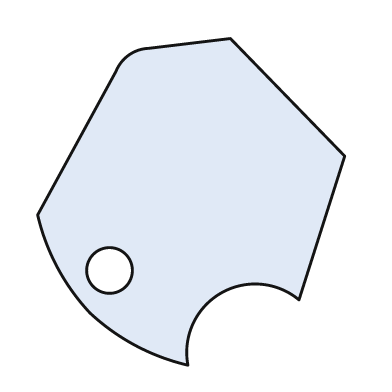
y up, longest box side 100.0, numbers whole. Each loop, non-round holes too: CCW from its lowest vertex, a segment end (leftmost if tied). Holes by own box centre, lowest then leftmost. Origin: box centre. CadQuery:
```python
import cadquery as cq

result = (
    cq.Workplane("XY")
    .moveTo(-1.0, -50.0)
    .threePointArc((9.0, -28.0), (33.0, -30.0))
    .lineTo(47.0, 14.0)
    .lineTo(12.0, 50.0)
    .lineTo(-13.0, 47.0)
    .threePointArc((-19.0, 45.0), (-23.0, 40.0))
    .lineTo(-47.0, -4.0)
    .threePointArc((-41.0, -20.0), (-31.0, -34.0))
    .threePointArc((-17.0, -44.0), (-1.0, -50.0))
    .close()
    .moveTo(-25.0, -21.0)
    .circle(7.0)
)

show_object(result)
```